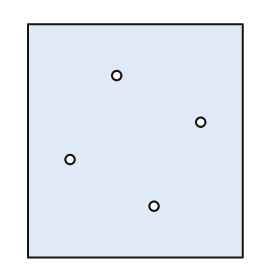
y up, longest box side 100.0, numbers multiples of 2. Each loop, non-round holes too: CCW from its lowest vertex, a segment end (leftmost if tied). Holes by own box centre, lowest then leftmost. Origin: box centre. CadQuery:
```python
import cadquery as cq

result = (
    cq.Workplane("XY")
    .moveTo(-46.0, -50.0)
    .lineTo(46.0, -50.0)
    .lineTo(46.0, 50.0)
    .lineTo(-46.0, 50.0)
    .close()
    .moveTo(8.0, -28.0)
    .circle(2.0)
    .moveTo(-28.0, -8.0)
    .circle(2.0)
    .moveTo(28.0, 8.0)
    .circle(2.0)
    .moveTo(-8.0, 28.0)
    .circle(2.0)
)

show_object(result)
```